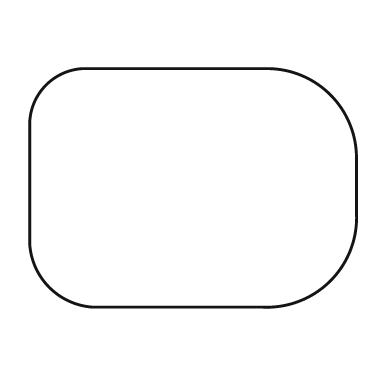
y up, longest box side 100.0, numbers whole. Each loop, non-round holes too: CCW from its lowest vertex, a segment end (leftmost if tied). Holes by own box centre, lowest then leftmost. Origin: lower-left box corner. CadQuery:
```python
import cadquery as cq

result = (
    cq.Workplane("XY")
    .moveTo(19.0, 0.0)
    .lineTo(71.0, 0.0)
    .threePointArc((92.0, 8.0), (100.0, 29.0))
    .lineTo(100.0, 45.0)
    .threePointArc((92.0, 65.0), (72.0, 73.0))
    .lineTo(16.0, 73.0)
    .threePointArc((5.0, 68.0), (0.0, 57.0))
    .lineTo(0.0, 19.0)
    .threePointArc((6.0, 6.0), (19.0, 0.0))
    .close()
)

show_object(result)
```